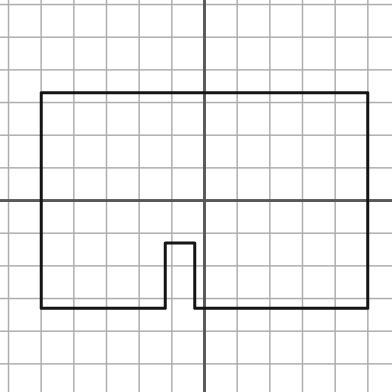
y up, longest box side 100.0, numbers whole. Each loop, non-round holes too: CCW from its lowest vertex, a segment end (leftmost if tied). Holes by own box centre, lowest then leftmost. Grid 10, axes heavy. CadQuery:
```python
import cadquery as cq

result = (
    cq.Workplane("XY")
    .moveTo(-50.0, -33.0)
    .lineTo(-12.0, -33.0)
    .lineTo(-12.0, -13.0)
    .lineTo(-3.0, -13.0)
    .lineTo(-3.0, -33.0)
    .lineTo(50.0, -33.0)
    .lineTo(50.0, 33.0)
    .lineTo(-50.0, 33.0)
    .close()
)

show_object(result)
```